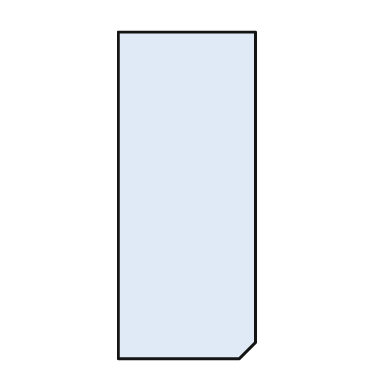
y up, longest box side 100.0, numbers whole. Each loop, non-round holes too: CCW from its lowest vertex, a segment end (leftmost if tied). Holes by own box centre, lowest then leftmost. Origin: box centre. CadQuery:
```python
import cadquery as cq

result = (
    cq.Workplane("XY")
    .moveTo(-21.0, -50.0)
    .lineTo(16.0, -50.0)
    .lineTo(21.0, -45.0)
    .lineTo(21.0, 50.0)
    .lineTo(-21.0, 50.0)
    .close()
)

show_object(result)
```